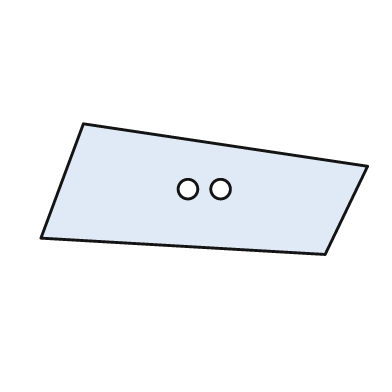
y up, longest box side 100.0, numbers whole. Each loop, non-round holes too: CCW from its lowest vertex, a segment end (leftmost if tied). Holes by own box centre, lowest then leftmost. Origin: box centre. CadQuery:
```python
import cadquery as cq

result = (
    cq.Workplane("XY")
    .moveTo(37.0, -20.0)
    .lineTo(50.0, 7.0)
    .lineTo(-37.0, 20.0)
    .lineTo(-50.0, -15.0)
    .close()
    .moveTo(-5.0, 0.0)
    .circle(3.0)
    .moveTo(5.0, 0.0)
    .circle(3.0)
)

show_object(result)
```